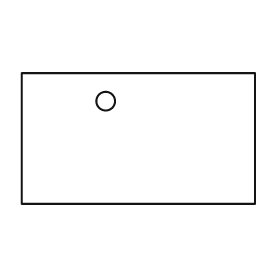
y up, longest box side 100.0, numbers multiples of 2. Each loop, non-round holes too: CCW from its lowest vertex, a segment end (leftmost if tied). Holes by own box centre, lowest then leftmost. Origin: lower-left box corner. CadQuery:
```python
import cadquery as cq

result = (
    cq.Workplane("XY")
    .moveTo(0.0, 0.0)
    .lineTo(100.0, 0.0)
    .lineTo(100.0, 56.0)
    .lineTo(0.0, 56.0)
    .close()
    .moveTo(36.0, 44.0)
    .circle(4.0)
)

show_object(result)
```